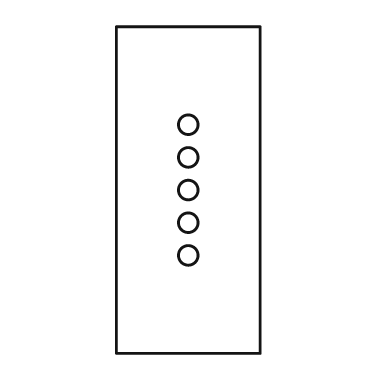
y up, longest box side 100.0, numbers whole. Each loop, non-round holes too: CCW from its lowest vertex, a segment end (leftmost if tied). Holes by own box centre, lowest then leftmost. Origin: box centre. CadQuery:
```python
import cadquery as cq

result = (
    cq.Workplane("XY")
    .moveTo(-22.0, -50.0)
    .lineTo(22.0, -50.0)
    .lineTo(22.0, 50.0)
    .lineTo(-22.0, 50.0)
    .close()
    .moveTo(0.0, -20.0)
    .circle(3.0)
    .moveTo(0.0, -10.0)
    .circle(3.0)
    .moveTo(0.0, 0.0)
    .circle(3.0)
    .moveTo(0.0, 10.0)
    .circle(3.0)
    .moveTo(0.0, 20.0)
    .circle(3.0)
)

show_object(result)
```